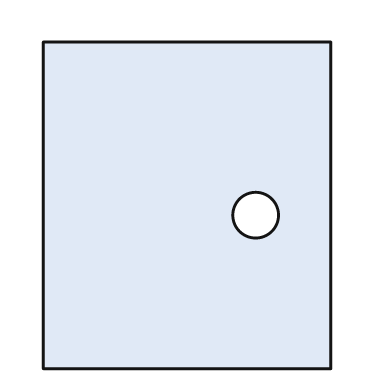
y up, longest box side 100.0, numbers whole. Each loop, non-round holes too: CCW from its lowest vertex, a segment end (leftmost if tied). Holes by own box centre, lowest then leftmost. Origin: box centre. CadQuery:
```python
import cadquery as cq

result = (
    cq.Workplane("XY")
    .moveTo(-44.0, -50.0)
    .lineTo(44.0, -50.0)
    .lineTo(44.0, 50.0)
    .lineTo(-44.0, 50.0)
    .close()
    .moveTo(21.0, -3.0)
    .circle(7.0)
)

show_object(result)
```